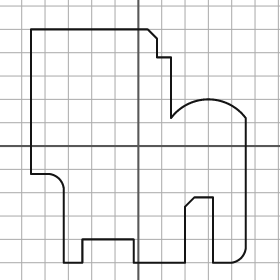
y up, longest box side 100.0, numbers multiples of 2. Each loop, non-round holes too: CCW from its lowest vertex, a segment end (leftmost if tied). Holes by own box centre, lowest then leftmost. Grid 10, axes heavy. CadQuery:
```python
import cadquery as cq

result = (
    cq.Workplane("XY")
    .moveTo(-32.0, -50.0)
    .lineTo(-24.0, -50.0)
    .lineTo(-24.0, -40.0)
    .lineTo(-2.0, -40.0)
    .lineTo(-2.0, -50.0)
    .lineTo(20.0, -50.0)
    .lineTo(20.0, -26.0)
    .lineTo(24.0, -22.0)
    .lineTo(32.0, -22.0)
    .lineTo(32.0, -50.0)
    .lineTo(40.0, -50.0)
    .threePointArc((44.0, -48.0), (46.0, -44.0))
    .lineTo(46.0, 12.0)
    .threePointArc((30.0, 20.0), (14.0, 12.0))
    .lineTo(14.0, 38.0)
    .lineTo(8.0, 38.0)
    .lineTo(8.0, 46.0)
    .lineTo(4.0, 50.0)
    .lineTo(-46.0, 50.0)
    .lineTo(-46.0, -12.0)
    .lineTo(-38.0, -12.0)
    .threePointArc((-34.0, -14.0), (-32.0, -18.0))
    .close()
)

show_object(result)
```